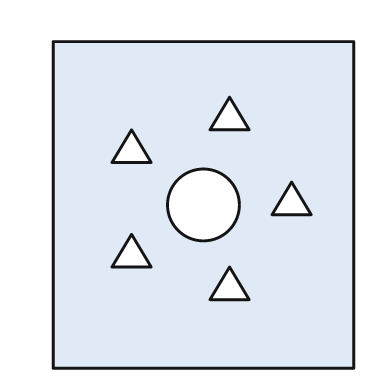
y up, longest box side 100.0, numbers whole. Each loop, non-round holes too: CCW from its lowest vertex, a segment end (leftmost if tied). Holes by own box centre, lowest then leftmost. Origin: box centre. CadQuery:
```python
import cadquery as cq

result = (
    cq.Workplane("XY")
    .moveTo(-46.0, -50.0)
    .lineTo(46.0, -50.0)
    .lineTo(46.0, 50.0)
    .lineTo(-46.0, 50.0)
    .close()
    .moveTo(2.0, -29.0)
    .lineTo(14.0, -29.0)
    .lineTo(8.0, -19.0)
    .close()
    .moveTo(-28.0, -19.0)
    .lineTo(-16.0, -19.0)
    .lineTo(-22.0, -9.0)
    .close()
    .moveTo(0.0, 0.0)
    .circle(11.0)
    .moveTo(21.0, -3.0)
    .lineTo(33.0, -3.0)
    .lineTo(27.0, 7.0)
    .close()
    .moveTo(-28.0, 13.0)
    .lineTo(-16.0, 13.0)
    .lineTo(-22.0, 23.0)
    .close()
    .moveTo(2.0, 23.0)
    .lineTo(14.0, 23.0)
    .lineTo(8.0, 33.0)
    .close()
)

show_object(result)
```